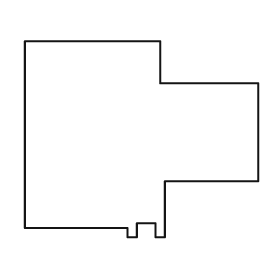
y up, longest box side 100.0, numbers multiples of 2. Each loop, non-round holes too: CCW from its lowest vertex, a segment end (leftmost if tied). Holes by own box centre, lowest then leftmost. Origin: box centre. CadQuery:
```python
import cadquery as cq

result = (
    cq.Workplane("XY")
    .moveTo(-6.0, -42.0)
    .lineTo(-2.0, -42.0)
    .lineTo(-2.0, -36.0)
    .lineTo(6.0, -36.0)
    .lineTo(6.0, -42.0)
    .lineTo(10.0, -42.0)
    .lineTo(10.0, -18.0)
    .lineTo(50.0, -18.0)
    .lineTo(50.0, 24.0)
    .lineTo(8.0, 24.0)
    .lineTo(8.0, 42.0)
    .lineTo(-50.0, 42.0)
    .lineTo(-50.0, -38.0)
    .lineTo(-6.0, -38.0)
    .close()
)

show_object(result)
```